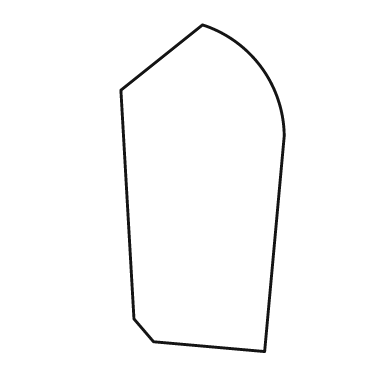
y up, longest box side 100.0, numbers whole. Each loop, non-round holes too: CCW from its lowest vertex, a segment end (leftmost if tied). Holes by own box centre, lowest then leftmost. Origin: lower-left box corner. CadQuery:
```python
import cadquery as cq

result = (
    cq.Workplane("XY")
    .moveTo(44.0, 0.0)
    .lineTo(50.0, 66.0)
    .threePointArc((43.0, 87.0), (25.0, 100.0))
    .lineTo(0.0, 80.0)
    .lineTo(4.0, 10.0)
    .lineTo(10.0, 3.0)
    .close()
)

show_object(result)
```